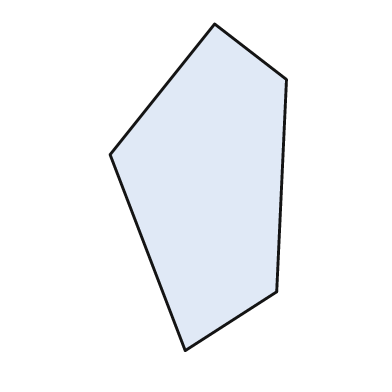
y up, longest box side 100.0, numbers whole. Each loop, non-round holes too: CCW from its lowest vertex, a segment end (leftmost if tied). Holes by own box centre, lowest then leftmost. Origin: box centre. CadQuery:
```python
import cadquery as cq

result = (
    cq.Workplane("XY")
    .moveTo(-4.0, -50.0)
    .lineTo(24.0, -32.0)
    .lineTo(27.0, 33.0)
    .lineTo(5.0, 50.0)
    .lineTo(-27.0, 10.0)
    .close()
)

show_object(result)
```